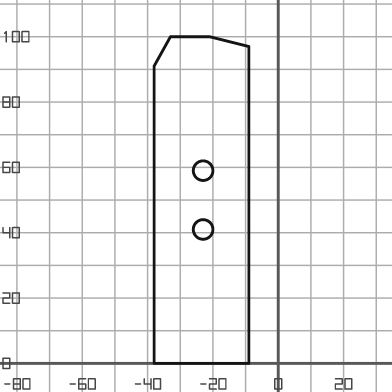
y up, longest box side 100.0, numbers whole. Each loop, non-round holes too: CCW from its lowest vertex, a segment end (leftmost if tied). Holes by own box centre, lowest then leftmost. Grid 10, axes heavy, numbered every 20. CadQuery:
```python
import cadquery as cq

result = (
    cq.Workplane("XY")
    .moveTo(-38.0, 0.0)
    .lineTo(-9.0, 0.0)
    .lineTo(-9.0, 97.0)
    .lineTo(-21.0, 100.0)
    .lineTo(-33.0, 100.0)
    .lineTo(-38.0, 91.0)
    .close()
    .moveTo(-23.0, 41.0)
    .circle(3.0)
    .moveTo(-23.0, 59.0)
    .circle(3.0)
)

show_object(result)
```